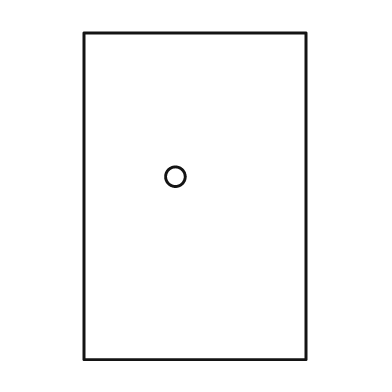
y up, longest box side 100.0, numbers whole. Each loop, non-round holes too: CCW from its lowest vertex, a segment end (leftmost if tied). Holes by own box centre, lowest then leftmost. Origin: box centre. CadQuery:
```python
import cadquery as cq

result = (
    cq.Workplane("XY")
    .moveTo(-34.0, -50.0)
    .lineTo(34.0, -50.0)
    .lineTo(34.0, 50.0)
    .lineTo(-34.0, 50.0)
    .close()
    .moveTo(-6.0, 6.0)
    .circle(3.0)
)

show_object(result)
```